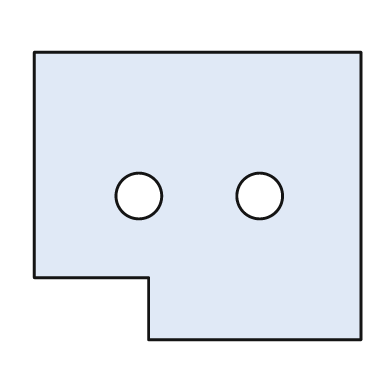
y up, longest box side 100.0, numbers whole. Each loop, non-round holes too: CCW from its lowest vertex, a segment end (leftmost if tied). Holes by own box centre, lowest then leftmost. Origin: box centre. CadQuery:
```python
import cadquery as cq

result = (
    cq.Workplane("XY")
    .moveTo(-15.0, -44.0)
    .lineTo(50.0, -44.0)
    .lineTo(50.0, 44.0)
    .lineTo(-50.0, 44.0)
    .lineTo(-50.0, -25.0)
    .lineTo(-15.0, -25.0)
    .close()
    .moveTo(-18.0, 0.0)
    .circle(7.0)
    .moveTo(19.0, 0.0)
    .circle(7.0)
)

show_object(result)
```